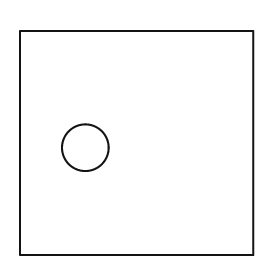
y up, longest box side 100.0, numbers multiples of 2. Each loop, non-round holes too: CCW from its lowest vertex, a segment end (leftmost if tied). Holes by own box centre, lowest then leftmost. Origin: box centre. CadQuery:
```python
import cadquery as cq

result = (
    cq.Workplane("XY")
    .moveTo(-50.0, -48.0)
    .lineTo(50.0, -48.0)
    .lineTo(50.0, 48.0)
    .lineTo(-50.0, 48.0)
    .close()
    .moveTo(-22.0, -2.0)
    .circle(10.0)
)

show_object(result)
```